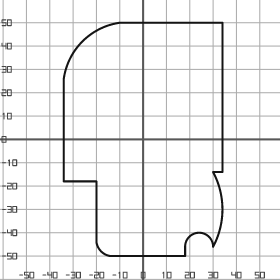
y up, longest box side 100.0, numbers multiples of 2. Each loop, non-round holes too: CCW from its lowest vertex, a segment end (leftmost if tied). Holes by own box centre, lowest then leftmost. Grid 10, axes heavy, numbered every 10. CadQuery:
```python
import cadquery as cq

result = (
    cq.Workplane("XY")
    .moveTo(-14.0, -50.0)
    .lineTo(18.0, -50.0)
    .lineTo(18.0, -46.0)
    .threePointArc((24.0, -40.0), (30.0, -46.0))
    .threePointArc((34.0, -30.0), (30.0, -14.0))
    .lineTo(34.0, -14.0)
    .lineTo(34.0, 50.0)
    .lineTo(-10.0, 50.0)
    .threePointArc((-26.0, 42.0), (-34.0, 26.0))
    .lineTo(-34.0, -18.0)
    .lineTo(-20.0, -18.0)
    .lineTo(-20.0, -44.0)
    .threePointArc((-18.0, -48.0), (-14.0, -50.0))
    .close()
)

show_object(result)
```